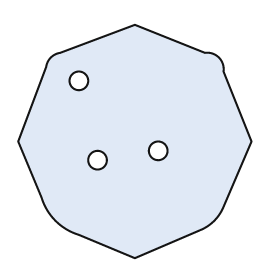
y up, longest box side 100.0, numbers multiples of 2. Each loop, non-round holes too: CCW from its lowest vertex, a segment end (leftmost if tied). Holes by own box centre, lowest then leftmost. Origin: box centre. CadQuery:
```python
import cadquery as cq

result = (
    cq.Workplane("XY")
    .moveTo(0.0, -50.0)
    .lineTo(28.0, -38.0)
    .threePointArc((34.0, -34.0), (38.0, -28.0))
    .lineTo(50.0, 0.0)
    .lineTo(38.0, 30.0)
    .threePointArc((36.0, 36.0), (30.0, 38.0))
    .lineTo(0.0, 50.0)
    .lineTo(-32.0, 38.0)
    .threePointArc((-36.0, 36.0), (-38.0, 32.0))
    .lineTo(-50.0, 0.0)
    .lineTo(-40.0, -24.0)
    .threePointArc((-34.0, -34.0), (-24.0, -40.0))
    .close()
    .moveTo(-16.0, -8.0)
    .circle(4.0)
    .moveTo(10.0, -4.0)
    .circle(4.0)
    .moveTo(-24.0, 26.0)
    .circle(4.0)
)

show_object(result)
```